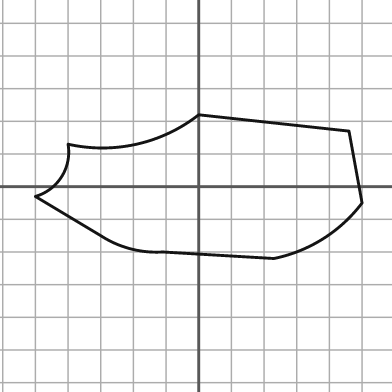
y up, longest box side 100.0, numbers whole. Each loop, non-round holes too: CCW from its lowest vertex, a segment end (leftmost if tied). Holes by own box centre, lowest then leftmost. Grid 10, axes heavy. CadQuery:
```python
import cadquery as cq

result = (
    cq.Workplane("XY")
    .moveTo(23.0, -22.0)
    .threePointArc((38.0, -16.0), (50.0, -5.0))
    .lineTo(46.0, 17.0)
    .lineTo(0.0, 22.0)
    .threePointArc((-19.0, 13.0), (-40.0, 13.0))
    .threePointArc((-42.0, 3.0), (-50.0, -3.0))
    .lineTo(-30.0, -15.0)
    .threePointArc((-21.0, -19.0), (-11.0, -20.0))
    .close()
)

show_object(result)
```